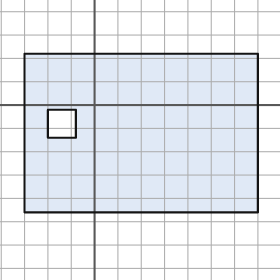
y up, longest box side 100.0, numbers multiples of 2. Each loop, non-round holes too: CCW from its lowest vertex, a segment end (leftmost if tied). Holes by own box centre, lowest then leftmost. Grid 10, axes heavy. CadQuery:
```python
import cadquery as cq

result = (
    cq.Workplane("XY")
    .moveTo(-30.0, -46.0)
    .lineTo(70.0, -46.0)
    .lineTo(70.0, 22.0)
    .lineTo(-30.0, 22.0)
    .close()
    .moveTo(-20.0, -14.0)
    .lineTo(-8.0, -14.0)
    .lineTo(-8.0, -2.0)
    .lineTo(-20.0, -2.0)
    .close()
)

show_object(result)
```